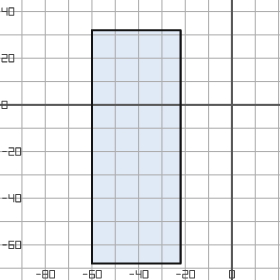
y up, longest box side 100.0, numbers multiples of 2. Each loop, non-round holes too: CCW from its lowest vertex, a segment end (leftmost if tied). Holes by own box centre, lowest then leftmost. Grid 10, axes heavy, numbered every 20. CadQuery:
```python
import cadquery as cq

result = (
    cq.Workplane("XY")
    .moveTo(-60.0, -68.0)
    .lineTo(-22.0, -68.0)
    .lineTo(-22.0, 32.0)
    .lineTo(-60.0, 32.0)
    .close()
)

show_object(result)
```